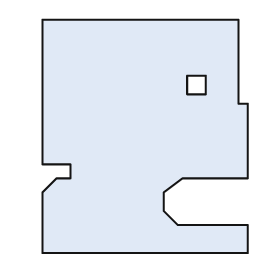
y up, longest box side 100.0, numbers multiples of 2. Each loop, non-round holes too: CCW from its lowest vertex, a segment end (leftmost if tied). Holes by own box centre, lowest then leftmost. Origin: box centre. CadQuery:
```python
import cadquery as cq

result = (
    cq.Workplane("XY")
    .moveTo(-44.0, -50.0)
    .lineTo(44.0, -50.0)
    .lineTo(44.0, -38.0)
    .lineTo(14.0, -38.0)
    .lineTo(8.0, -32.0)
    .lineTo(8.0, -24.0)
    .lineTo(16.0, -18.0)
    .lineTo(44.0, -18.0)
    .lineTo(44.0, 14.0)
    .lineTo(40.0, 14.0)
    .lineTo(40.0, 50.0)
    .lineTo(-44.0, 50.0)
    .lineTo(-44.0, -12.0)
    .lineTo(-32.0, -12.0)
    .lineTo(-32.0, -18.0)
    .lineTo(-38.0, -18.0)
    .lineTo(-44.0, -24.0)
    .close()
    .moveTo(18.0, 18.0)
    .lineTo(26.0, 18.0)
    .lineTo(26.0, 26.0)
    .lineTo(18.0, 26.0)
    .close()
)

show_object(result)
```